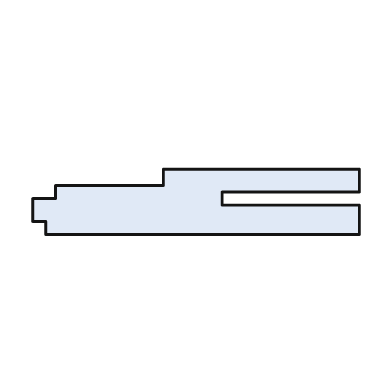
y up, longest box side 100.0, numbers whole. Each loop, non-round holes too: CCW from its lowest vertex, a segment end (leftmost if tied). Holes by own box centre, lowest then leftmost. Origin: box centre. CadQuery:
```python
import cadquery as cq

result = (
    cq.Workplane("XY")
    .moveTo(-46.0, -10.0)
    .lineTo(50.0, -10.0)
    .lineTo(50.0, -1.0)
    .lineTo(8.0, -1.0)
    .lineTo(8.0, 3.0)
    .lineTo(50.0, 3.0)
    .lineTo(50.0, 10.0)
    .lineTo(-10.0, 10.0)
    .lineTo(-10.0, 5.0)
    .lineTo(-43.0, 5.0)
    .lineTo(-43.0, 1.0)
    .lineTo(-50.0, 1.0)
    .lineTo(-50.0, -6.0)
    .lineTo(-46.0, -6.0)
    .close()
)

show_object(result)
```